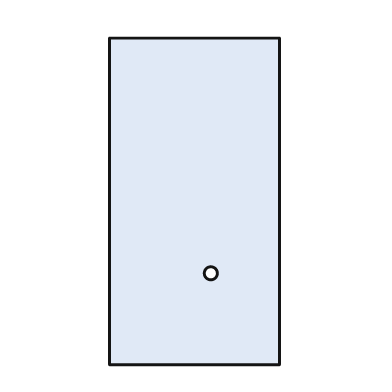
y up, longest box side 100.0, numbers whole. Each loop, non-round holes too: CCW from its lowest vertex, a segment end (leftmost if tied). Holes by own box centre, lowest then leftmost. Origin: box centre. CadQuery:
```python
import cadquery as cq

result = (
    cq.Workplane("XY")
    .moveTo(-26.0, -50.0)
    .lineTo(26.0, -50.0)
    .lineTo(26.0, 50.0)
    .lineTo(-26.0, 50.0)
    .close()
    .moveTo(5.0, -22.0)
    .circle(2.0)
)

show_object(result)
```